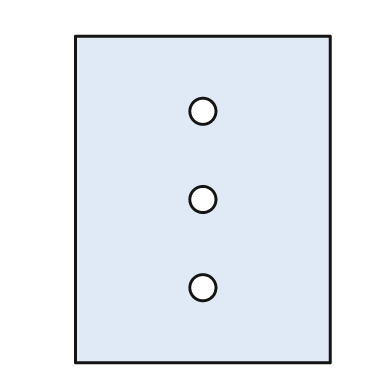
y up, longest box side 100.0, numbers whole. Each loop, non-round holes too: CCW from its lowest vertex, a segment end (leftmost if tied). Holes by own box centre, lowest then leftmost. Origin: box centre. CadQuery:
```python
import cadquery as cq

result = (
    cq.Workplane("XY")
    .moveTo(-39.0, -50.0)
    .lineTo(39.0, -50.0)
    .lineTo(39.0, 50.0)
    .lineTo(-39.0, 50.0)
    .close()
    .moveTo(0.0, -27.0)
    .circle(4.0)
    .moveTo(0.0, 0.0)
    .circle(4.0)
    .moveTo(0.0, 27.0)
    .circle(4.0)
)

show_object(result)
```